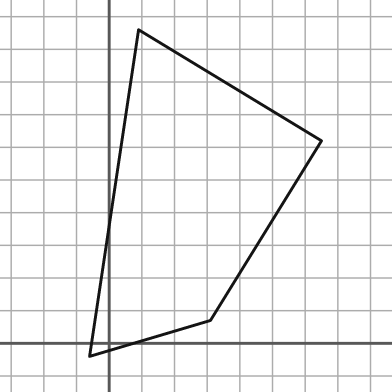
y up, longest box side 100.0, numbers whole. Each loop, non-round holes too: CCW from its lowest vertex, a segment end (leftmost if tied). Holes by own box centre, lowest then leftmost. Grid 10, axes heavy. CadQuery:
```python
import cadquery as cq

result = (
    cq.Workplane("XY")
    .moveTo(-6.0, -4.0)
    .lineTo(31.0, 7.0)
    .lineTo(65.0, 62.0)
    .lineTo(9.0, 96.0)
    .close()
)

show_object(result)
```